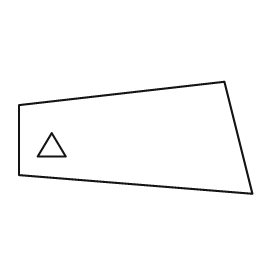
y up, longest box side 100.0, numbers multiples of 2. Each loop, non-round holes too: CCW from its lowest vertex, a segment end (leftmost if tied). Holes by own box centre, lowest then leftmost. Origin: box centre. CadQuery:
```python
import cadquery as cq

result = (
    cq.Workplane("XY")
    .moveTo(50.0, -24.0)
    .lineTo(38.0, 24.0)
    .lineTo(-50.0, 14.0)
    .lineTo(-50.0, -16.0)
    .close()
    .moveTo(-42.0, -8.0)
    .lineTo(-30.0, -8.0)
    .lineTo(-36.0, 2.0)
    .close()
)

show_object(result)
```